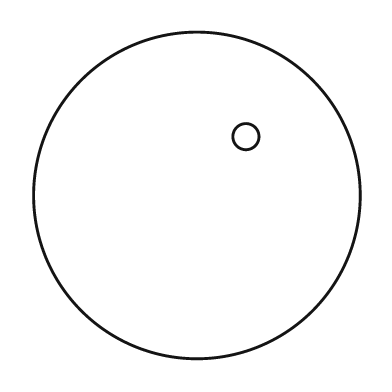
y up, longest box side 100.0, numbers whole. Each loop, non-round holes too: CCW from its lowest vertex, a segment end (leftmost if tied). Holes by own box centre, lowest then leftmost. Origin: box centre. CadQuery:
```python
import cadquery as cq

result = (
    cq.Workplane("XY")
    .moveTo(0.0, 0.0)
    .circle(50.0)
    .moveTo(15.0, 18.0)
    .circle(4.0)
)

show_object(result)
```